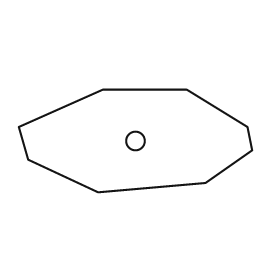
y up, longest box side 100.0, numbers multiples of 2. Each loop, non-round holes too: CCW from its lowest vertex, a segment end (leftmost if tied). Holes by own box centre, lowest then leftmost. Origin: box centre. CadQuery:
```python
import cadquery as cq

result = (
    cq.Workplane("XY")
    .moveTo(-16.0, -22.0)
    .lineTo(30.0, -18.0)
    .lineTo(50.0, -4.0)
    .lineTo(48.0, 6.0)
    .lineTo(22.0, 22.0)
    .lineTo(-14.0, 22.0)
    .lineTo(-50.0, 6.0)
    .lineTo(-46.0, -8.0)
    .close()
    .moveTo(0.0, 0.0)
    .circle(4.0)
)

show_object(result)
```